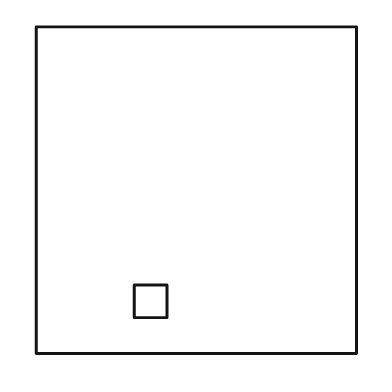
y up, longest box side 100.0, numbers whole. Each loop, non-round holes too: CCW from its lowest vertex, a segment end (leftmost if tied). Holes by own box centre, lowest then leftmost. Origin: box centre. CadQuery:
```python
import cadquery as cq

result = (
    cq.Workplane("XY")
    .moveTo(-49.0, -50.0)
    .lineTo(49.0, -50.0)
    .lineTo(49.0, 50.0)
    .lineTo(-49.0, 50.0)
    .close()
    .moveTo(-19.0, -39.0)
    .lineTo(-9.0, -39.0)
    .lineTo(-9.0, -29.0)
    .lineTo(-19.0, -29.0)
    .close()
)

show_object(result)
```